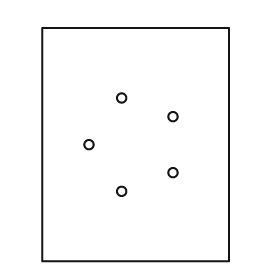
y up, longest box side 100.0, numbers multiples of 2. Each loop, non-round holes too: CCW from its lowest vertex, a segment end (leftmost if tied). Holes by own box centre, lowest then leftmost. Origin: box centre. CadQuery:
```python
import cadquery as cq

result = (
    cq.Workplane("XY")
    .moveTo(-40.0, -50.0)
    .lineTo(40.0, -50.0)
    .lineTo(40.0, 50.0)
    .lineTo(-40.0, 50.0)
    .close()
    .moveTo(-6.0, -20.0)
    .circle(2.0)
    .moveTo(16.0, -12.0)
    .circle(2.0)
    .moveTo(-20.0, 0.0)
    .circle(2.0)
    .moveTo(16.0, 12.0)
    .circle(2.0)
    .moveTo(-6.0, 20.0)
    .circle(2.0)
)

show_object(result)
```